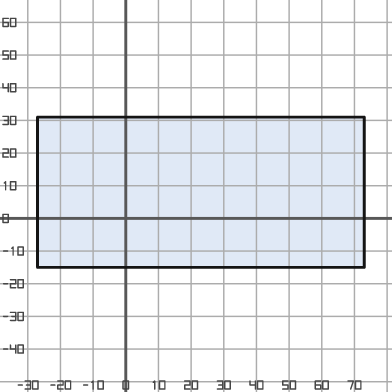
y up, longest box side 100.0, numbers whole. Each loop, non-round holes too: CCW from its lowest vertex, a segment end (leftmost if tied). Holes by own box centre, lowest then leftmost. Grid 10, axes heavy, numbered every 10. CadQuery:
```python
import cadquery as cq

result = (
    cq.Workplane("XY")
    .moveTo(-27.0, -15.0)
    .lineTo(73.0, -15.0)
    .lineTo(73.0, 31.0)
    .lineTo(-27.0, 31.0)
    .close()
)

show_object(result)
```